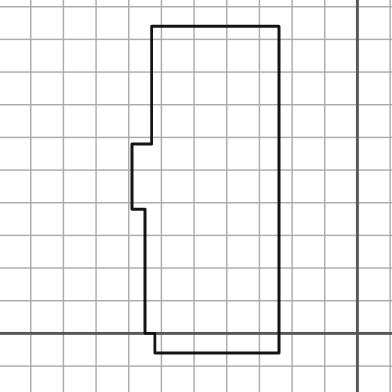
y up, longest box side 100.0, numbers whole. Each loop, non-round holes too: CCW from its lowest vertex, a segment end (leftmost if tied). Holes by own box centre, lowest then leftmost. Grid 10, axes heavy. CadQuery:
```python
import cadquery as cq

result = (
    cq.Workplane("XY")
    .moveTo(-62.0, -6.0)
    .lineTo(-24.0, -6.0)
    .lineTo(-24.0, 94.0)
    .lineTo(-63.0, 94.0)
    .lineTo(-63.0, 58.0)
    .lineTo(-69.0, 58.0)
    .lineTo(-69.0, 38.0)
    .lineTo(-65.0, 38.0)
    .lineTo(-65.0, 0.0)
    .lineTo(-62.0, 0.0)
    .close()
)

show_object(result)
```